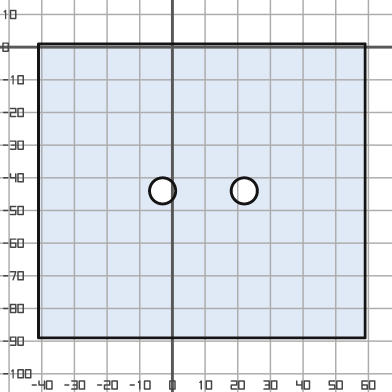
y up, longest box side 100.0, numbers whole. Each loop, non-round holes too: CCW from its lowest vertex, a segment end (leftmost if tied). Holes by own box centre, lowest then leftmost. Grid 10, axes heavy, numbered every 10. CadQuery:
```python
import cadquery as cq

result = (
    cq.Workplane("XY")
    .moveTo(-41.0, -89.0)
    .lineTo(59.0, -89.0)
    .lineTo(59.0, 1.0)
    .lineTo(-41.0, 1.0)
    .close()
    .moveTo(-3.0, -44.0)
    .circle(4.0)
    .moveTo(22.0, -44.0)
    .circle(4.0)
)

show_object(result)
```